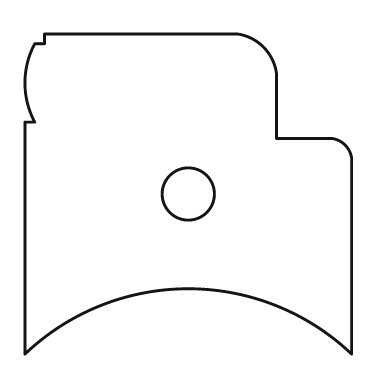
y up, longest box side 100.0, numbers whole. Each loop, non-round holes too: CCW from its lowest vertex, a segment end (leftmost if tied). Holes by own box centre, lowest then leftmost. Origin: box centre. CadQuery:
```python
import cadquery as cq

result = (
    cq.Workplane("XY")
    .moveTo(-50.0, -49.0)
    .threePointArc((0.0, -29.0), (50.0, -49.0))
    .lineTo(50.0, 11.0)
    .threePointArc((48.0, 15.0), (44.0, 17.0))
    .lineTo(27.0, 17.0)
    .lineTo(27.0, 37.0)
    .threePointArc((23.0, 45.0), (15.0, 49.0))
    .lineTo(-44.0, 49.0)
    .lineTo(-44.0, 46.0)
    .lineTo(-47.0, 46.0)
    .threePointArc((-50.0, 34.0), (-47.0, 22.0))
    .lineTo(-50.0, 22.0)
    .close()
    .moveTo(0.0, 0.0)
    .circle(8.0)
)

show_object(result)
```